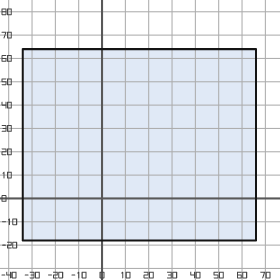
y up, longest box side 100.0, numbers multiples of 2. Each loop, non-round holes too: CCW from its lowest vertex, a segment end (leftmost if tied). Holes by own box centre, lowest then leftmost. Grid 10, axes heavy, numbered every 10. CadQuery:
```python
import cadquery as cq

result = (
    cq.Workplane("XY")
    .moveTo(-34.0, -18.0)
    .lineTo(66.0, -18.0)
    .lineTo(66.0, 64.0)
    .lineTo(-34.0, 64.0)
    .close()
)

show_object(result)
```